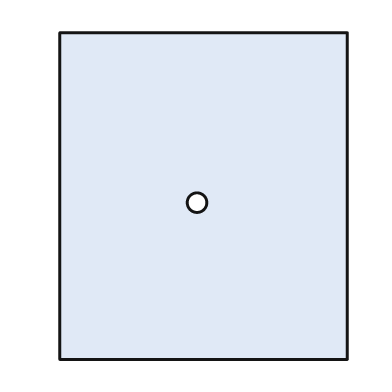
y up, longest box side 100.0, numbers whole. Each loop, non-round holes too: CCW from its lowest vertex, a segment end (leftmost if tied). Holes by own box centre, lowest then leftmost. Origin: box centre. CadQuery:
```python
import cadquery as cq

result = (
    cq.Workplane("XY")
    .moveTo(-44.0, -50.0)
    .lineTo(44.0, -50.0)
    .lineTo(44.0, 50.0)
    .lineTo(-44.0, 50.0)
    .close()
    .moveTo(-2.0, -2.0)
    .circle(3.0)
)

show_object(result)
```